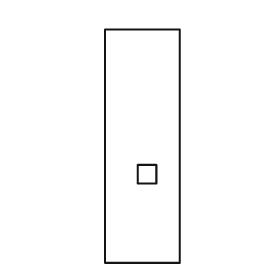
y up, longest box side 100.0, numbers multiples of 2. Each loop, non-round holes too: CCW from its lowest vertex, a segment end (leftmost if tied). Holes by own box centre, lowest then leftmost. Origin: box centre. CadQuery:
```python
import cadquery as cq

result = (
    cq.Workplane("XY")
    .moveTo(-16.0, -50.0)
    .lineTo(16.0, -50.0)
    .lineTo(16.0, 50.0)
    .lineTo(-16.0, 50.0)
    .close()
    .moveTo(-2.0, -16.0)
    .lineTo(6.0, -16.0)
    .lineTo(6.0, -8.0)
    .lineTo(-2.0, -8.0)
    .close()
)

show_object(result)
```